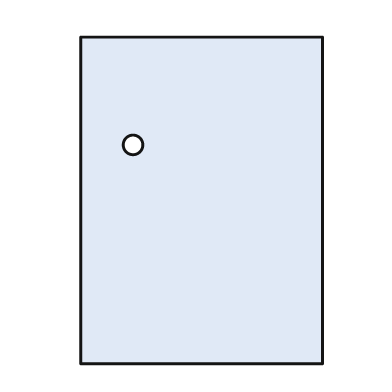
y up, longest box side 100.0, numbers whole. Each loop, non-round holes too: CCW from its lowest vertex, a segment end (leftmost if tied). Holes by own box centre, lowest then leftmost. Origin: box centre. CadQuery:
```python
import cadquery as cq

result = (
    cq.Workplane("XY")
    .moveTo(-37.0, -50.0)
    .lineTo(37.0, -50.0)
    .lineTo(37.0, 50.0)
    .lineTo(-37.0, 50.0)
    .close()
    .moveTo(-21.0, 17.0)
    .circle(3.0)
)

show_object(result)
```